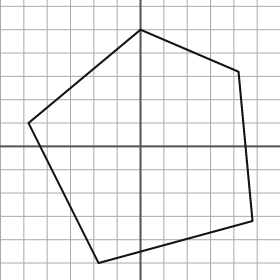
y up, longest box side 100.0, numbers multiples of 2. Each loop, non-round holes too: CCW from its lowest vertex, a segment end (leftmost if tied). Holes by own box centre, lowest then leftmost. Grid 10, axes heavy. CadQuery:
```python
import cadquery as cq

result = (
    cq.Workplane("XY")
    .moveTo(-18.0, -50.0)
    .lineTo(48.0, -32.0)
    .lineTo(42.0, 32.0)
    .lineTo(0.0, 50.0)
    .lineTo(-48.0, 10.0)
    .close()
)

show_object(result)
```